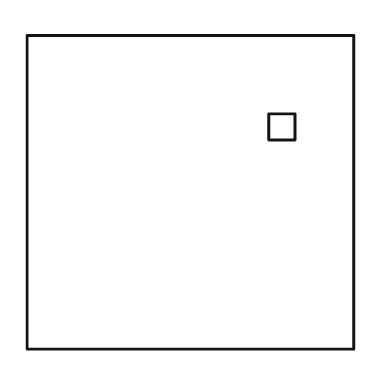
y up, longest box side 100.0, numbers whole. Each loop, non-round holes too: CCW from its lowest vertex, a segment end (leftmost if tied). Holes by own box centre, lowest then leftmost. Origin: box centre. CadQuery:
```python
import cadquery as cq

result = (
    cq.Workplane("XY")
    .moveTo(-50.0, -48.0)
    .lineTo(50.0, -48.0)
    .lineTo(50.0, 48.0)
    .lineTo(-50.0, 48.0)
    .close()
    .moveTo(24.0, 16.0)
    .lineTo(32.0, 16.0)
    .lineTo(32.0, 24.0)
    .lineTo(24.0, 24.0)
    .close()
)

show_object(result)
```